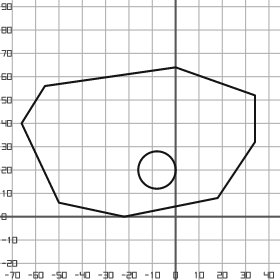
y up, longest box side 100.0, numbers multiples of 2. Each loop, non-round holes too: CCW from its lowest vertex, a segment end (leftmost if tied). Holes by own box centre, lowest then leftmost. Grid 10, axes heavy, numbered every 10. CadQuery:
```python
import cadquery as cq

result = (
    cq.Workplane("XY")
    .moveTo(-22.0, 0.0)
    .lineTo(18.0, 8.0)
    .lineTo(34.0, 32.0)
    .lineTo(34.0, 52.0)
    .lineTo(0.0, 64.0)
    .lineTo(-56.0, 56.0)
    .lineTo(-66.0, 40.0)
    .lineTo(-50.0, 6.0)
    .close()
    .moveTo(-8.0, 20.0)
    .circle(8.0)
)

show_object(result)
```